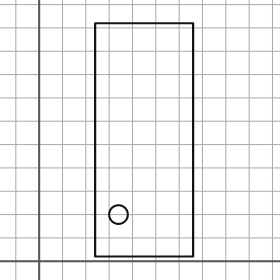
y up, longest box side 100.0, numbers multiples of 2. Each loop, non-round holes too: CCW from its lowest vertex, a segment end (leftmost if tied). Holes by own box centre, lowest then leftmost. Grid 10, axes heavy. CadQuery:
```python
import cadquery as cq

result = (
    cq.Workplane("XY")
    .moveTo(24.0, 2.0)
    .lineTo(66.0, 2.0)
    .lineTo(66.0, 102.0)
    .lineTo(24.0, 102.0)
    .close()
    .moveTo(34.0, 20.0)
    .circle(4.0)
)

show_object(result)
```